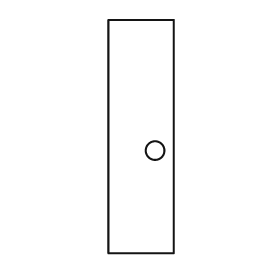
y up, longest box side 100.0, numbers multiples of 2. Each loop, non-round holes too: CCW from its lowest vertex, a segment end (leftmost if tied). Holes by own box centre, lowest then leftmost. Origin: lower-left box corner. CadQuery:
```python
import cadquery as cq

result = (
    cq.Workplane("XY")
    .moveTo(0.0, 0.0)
    .lineTo(28.0, 0.0)
    .lineTo(28.0, 100.0)
    .lineTo(0.0, 100.0)
    .close()
    .moveTo(20.0, 44.0)
    .circle(4.0)
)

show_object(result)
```